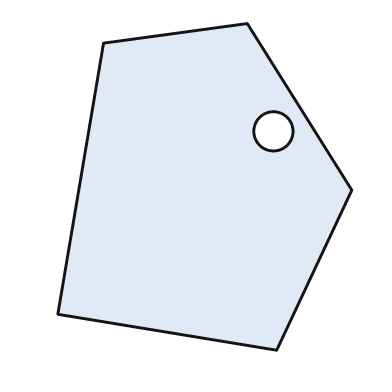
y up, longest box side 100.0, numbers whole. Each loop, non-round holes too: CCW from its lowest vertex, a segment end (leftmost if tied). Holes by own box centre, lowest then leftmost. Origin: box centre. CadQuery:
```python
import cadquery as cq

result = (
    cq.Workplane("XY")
    .moveTo(22.0, -50.0)
    .lineTo(45.0, -1.0)
    .lineTo(13.0, 50.0)
    .lineTo(-31.0, 44.0)
    .lineTo(-45.0, -39.0)
    .close()
    .moveTo(21.0, 17.0)
    .circle(6.0)
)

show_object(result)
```